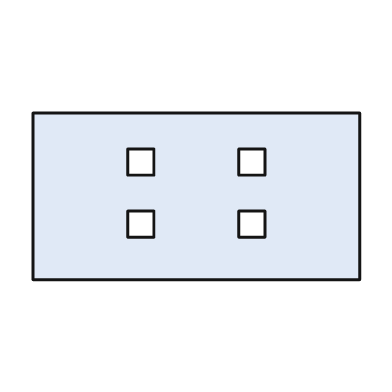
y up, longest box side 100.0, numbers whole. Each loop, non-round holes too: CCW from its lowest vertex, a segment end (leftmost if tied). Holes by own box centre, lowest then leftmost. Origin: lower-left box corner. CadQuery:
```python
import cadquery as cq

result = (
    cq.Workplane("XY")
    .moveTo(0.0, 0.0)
    .lineTo(100.0, 0.0)
    .lineTo(100.0, 51.0)
    .lineTo(0.0, 51.0)
    .close()
    .moveTo(29.0, 13.0)
    .lineTo(37.0, 13.0)
    .lineTo(37.0, 21.0)
    .lineTo(29.0, 21.0)
    .close()
    .moveTo(63.0, 13.0)
    .lineTo(71.0, 13.0)
    .lineTo(71.0, 21.0)
    .lineTo(63.0, 21.0)
    .close()
    .moveTo(29.0, 32.0)
    .lineTo(37.0, 32.0)
    .lineTo(37.0, 40.0)
    .lineTo(29.0, 40.0)
    .close()
    .moveTo(63.0, 32.0)
    .lineTo(71.0, 32.0)
    .lineTo(71.0, 40.0)
    .lineTo(63.0, 40.0)
    .close()
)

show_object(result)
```